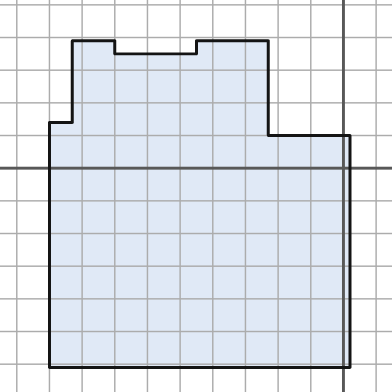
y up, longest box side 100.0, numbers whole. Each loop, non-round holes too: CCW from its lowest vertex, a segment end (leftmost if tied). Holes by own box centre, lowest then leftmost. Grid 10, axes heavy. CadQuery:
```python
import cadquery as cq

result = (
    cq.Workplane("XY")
    .moveTo(-90.0, -61.0)
    .lineTo(2.0, -61.0)
    .lineTo(2.0, 10.0)
    .lineTo(-23.0, 10.0)
    .lineTo(-23.0, 39.0)
    .lineTo(-45.0, 39.0)
    .lineTo(-45.0, 35.0)
    .lineTo(-70.0, 35.0)
    .lineTo(-70.0, 39.0)
    .lineTo(-83.0, 39.0)
    .lineTo(-83.0, 14.0)
    .lineTo(-90.0, 14.0)
    .close()
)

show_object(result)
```